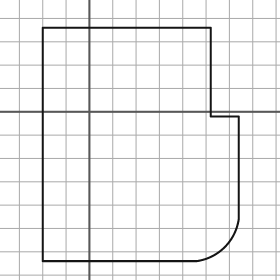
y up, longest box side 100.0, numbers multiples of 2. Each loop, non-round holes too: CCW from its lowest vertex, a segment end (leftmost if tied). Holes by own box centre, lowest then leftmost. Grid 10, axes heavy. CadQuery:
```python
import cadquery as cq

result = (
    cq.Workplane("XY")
    .moveTo(-20.0, -64.0)
    .lineTo(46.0, -64.0)
    .threePointArc((58.0, -58.0), (64.0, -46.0))
    .lineTo(64.0, -2.0)
    .lineTo(52.0, -2.0)
    .lineTo(52.0, 36.0)
    .lineTo(-20.0, 36.0)
    .close()
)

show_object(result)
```